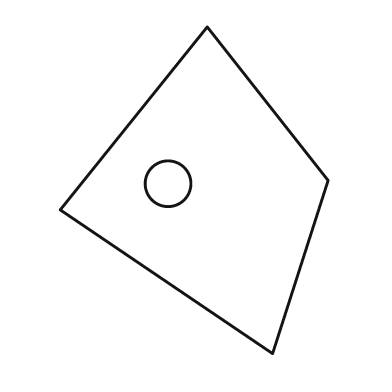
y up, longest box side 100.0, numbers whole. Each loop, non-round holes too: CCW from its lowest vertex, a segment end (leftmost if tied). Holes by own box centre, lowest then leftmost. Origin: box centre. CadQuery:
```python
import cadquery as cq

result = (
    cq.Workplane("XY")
    .moveTo(24.0, -50.0)
    .lineTo(41.0, 3.0)
    .lineTo(4.0, 50.0)
    .lineTo(-41.0, -6.0)
    .close()
    .moveTo(-8.0, 2.0)
    .circle(7.0)
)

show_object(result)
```